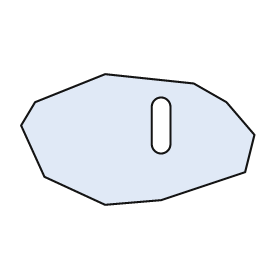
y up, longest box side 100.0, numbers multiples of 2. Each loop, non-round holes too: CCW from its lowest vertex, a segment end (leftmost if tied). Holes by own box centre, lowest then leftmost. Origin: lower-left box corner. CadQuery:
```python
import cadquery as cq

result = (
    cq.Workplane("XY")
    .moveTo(36.0, 0.0)
    .lineTo(60.0, 2.0)
    .lineTo(96.0, 14.0)
    .lineTo(100.0, 30.0)
    .lineTo(88.0, 44.0)
    .lineTo(74.0, 52.0)
    .lineTo(36.0, 56.0)
    .lineTo(6.0, 44.0)
    .lineTo(0.0, 34.0)
    .lineTo(10.0, 12.0)
    .close()
    .moveTo(56.0, 26.0)
    .threePointArc((60.0, 22.0), (64.0, 26.0))
    .lineTo(64.0, 42.0)
    .threePointArc((60.0, 46.0), (56.0, 42.0))
    .close()
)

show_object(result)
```